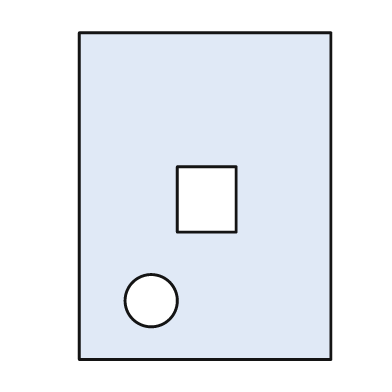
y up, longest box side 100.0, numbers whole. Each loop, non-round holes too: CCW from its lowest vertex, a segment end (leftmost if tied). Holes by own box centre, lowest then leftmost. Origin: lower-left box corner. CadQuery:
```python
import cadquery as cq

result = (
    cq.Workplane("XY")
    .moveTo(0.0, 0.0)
    .lineTo(77.0, 0.0)
    .lineTo(77.0, 100.0)
    .lineTo(0.0, 100.0)
    .close()
    .moveTo(22.0, 18.0)
    .circle(8.0)
    .moveTo(30.0, 39.0)
    .lineTo(48.0, 39.0)
    .lineTo(48.0, 59.0)
    .lineTo(30.0, 59.0)
    .close()
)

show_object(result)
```